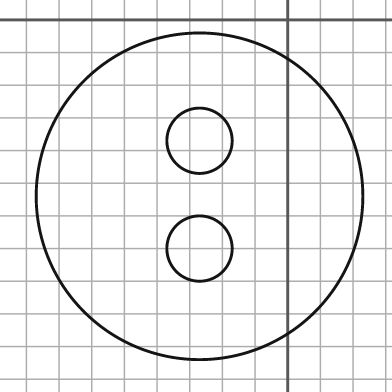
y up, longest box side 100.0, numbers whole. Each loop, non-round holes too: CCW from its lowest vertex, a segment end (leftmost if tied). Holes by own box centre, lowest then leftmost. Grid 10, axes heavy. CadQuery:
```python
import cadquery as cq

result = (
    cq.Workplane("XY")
    .moveTo(-27.0, -54.0)
    .circle(50.0)
    .moveTo(-27.0, -70.0)
    .circle(10.0)
    .moveTo(-27.0, -37.0)
    .circle(10.0)
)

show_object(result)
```